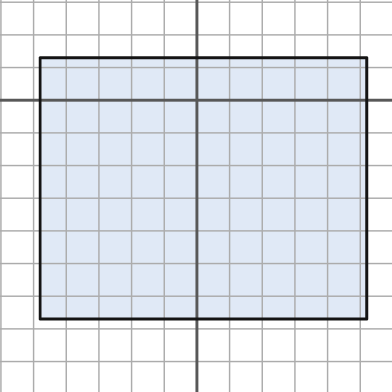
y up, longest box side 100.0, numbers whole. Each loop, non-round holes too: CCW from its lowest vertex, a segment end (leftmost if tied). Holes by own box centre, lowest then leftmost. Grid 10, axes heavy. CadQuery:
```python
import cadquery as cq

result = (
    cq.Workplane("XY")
    .moveTo(-48.0, -67.0)
    .lineTo(52.0, -67.0)
    .lineTo(52.0, 13.0)
    .lineTo(-48.0, 13.0)
    .close()
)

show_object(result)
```